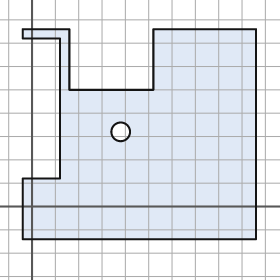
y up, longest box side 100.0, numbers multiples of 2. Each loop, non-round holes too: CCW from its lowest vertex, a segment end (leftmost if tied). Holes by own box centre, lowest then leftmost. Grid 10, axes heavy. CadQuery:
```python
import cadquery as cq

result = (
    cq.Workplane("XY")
    .moveTo(-4.0, -14.0)
    .lineTo(96.0, -14.0)
    .lineTo(96.0, 76.0)
    .lineTo(52.0, 76.0)
    .lineTo(52.0, 50.0)
    .lineTo(16.0, 50.0)
    .lineTo(16.0, 76.0)
    .lineTo(-4.0, 76.0)
    .lineTo(-4.0, 72.0)
    .lineTo(12.0, 72.0)
    .lineTo(12.0, 12.0)
    .lineTo(-4.0, 12.0)
    .close()
    .moveTo(38.0, 32.0)
    .circle(4.0)
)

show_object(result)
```